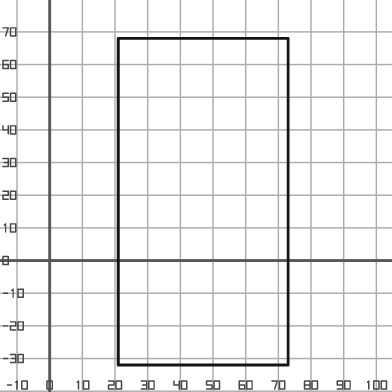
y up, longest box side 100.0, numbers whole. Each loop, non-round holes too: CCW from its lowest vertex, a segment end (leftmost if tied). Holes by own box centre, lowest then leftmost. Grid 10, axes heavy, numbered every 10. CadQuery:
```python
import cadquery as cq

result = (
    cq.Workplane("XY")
    .moveTo(21.0, -32.0)
    .lineTo(73.0, -32.0)
    .lineTo(73.0, 68.0)
    .lineTo(21.0, 68.0)
    .close()
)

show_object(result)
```